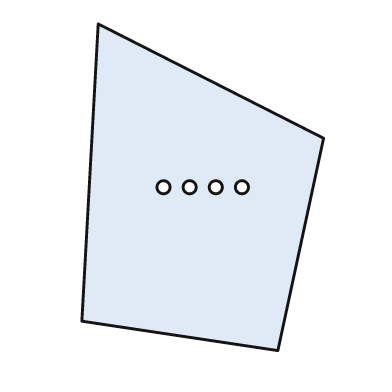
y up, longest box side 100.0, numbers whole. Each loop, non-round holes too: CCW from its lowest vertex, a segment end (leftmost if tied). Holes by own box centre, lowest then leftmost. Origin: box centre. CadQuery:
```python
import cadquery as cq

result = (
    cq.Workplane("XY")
    .moveTo(23.0, -50.0)
    .lineTo(37.0, 15.0)
    .lineTo(-32.0, 50.0)
    .lineTo(-37.0, -41.0)
    .close()
    .moveTo(-12.0, 0.0)
    .circle(2.0)
    .moveTo(-4.0, 0.0)
    .circle(2.0)
    .moveTo(4.0, 0.0)
    .circle(2.0)
    .moveTo(12.0, 0.0)
    .circle(2.0)
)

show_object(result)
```